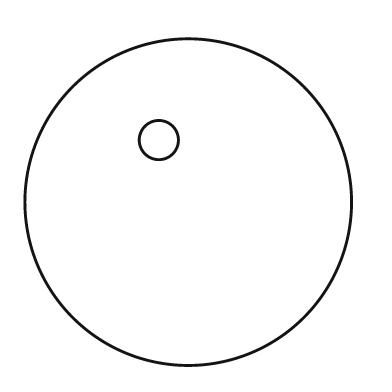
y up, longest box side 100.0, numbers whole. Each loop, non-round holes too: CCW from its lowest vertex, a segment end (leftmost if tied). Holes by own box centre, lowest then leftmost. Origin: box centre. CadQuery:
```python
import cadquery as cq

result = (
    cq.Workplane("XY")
    .moveTo(0.0, 0.0)
    .circle(50.0)
    .moveTo(-9.0, 19.0)
    .circle(6.0)
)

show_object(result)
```